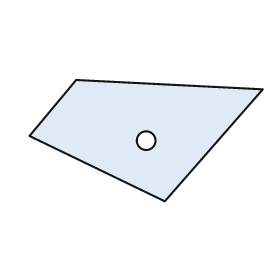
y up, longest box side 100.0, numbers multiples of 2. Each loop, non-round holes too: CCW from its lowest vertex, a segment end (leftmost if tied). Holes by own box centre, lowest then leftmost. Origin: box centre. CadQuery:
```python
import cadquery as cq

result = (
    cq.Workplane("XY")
    .moveTo(8.0, -26.0)
    .lineTo(50.0, 22.0)
    .lineTo(-30.0, 26.0)
    .lineTo(-50.0, 2.0)
    .close()
    .moveTo(0.0, 0.0)
    .circle(4.0)
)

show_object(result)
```